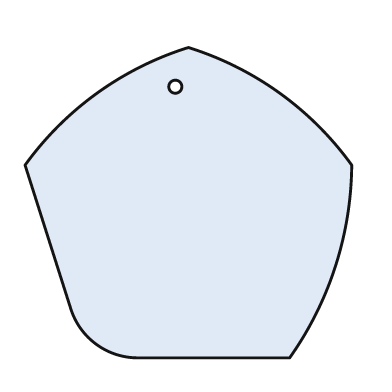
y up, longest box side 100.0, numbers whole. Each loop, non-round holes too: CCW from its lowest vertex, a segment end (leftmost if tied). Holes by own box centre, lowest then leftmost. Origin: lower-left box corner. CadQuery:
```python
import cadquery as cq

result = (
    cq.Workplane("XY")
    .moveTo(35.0, 0.0)
    .lineTo(81.0, 0.0)
    .threePointArc((95.0, 28.0), (100.0, 59.0))
    .threePointArc((78.0, 81.0), (50.0, 95.0))
    .threePointArc((22.0, 81.0), (0.0, 59.0))
    .lineTo(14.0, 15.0)
    .threePointArc((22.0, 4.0), (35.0, 0.0))
    .close()
    .moveTo(46.0, 83.0)
    .circle(2.0)
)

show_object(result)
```